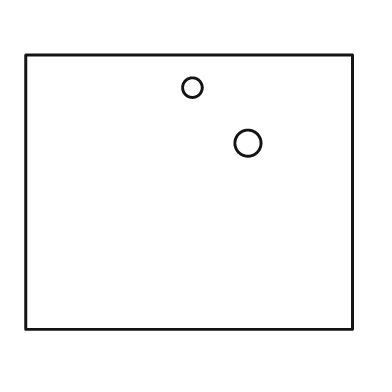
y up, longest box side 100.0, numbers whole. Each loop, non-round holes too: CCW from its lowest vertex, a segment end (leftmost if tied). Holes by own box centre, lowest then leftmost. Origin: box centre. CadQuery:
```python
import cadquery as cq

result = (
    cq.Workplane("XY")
    .moveTo(-50.0, -42.0)
    .lineTo(50.0, -42.0)
    .lineTo(50.0, 42.0)
    .lineTo(-50.0, 42.0)
    .close()
    .moveTo(18.0, 15.0)
    .circle(4.0)
    .moveTo(1.0, 32.0)
    .circle(3.0)
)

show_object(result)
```